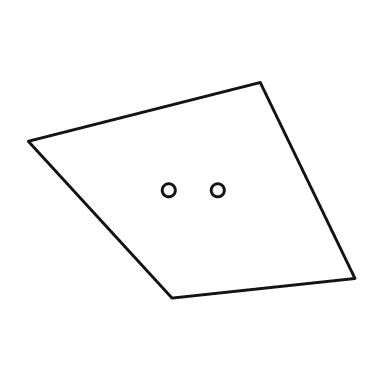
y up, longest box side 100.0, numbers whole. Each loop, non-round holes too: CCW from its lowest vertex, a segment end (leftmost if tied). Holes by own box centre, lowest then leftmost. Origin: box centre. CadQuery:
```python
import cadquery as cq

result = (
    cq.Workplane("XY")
    .moveTo(-6.0, -33.0)
    .lineTo(50.0, -27.0)
    .lineTo(21.0, 33.0)
    .lineTo(-50.0, 15.0)
    .close()
    .moveTo(-7.0, 0.0)
    .circle(2.0)
    .moveTo(8.0, 0.0)
    .circle(2.0)
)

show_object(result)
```